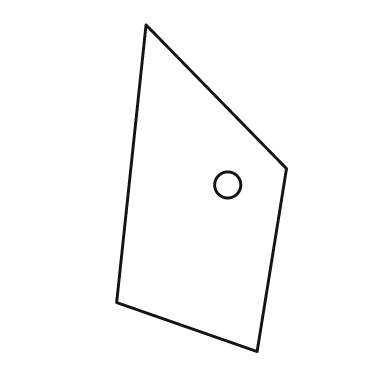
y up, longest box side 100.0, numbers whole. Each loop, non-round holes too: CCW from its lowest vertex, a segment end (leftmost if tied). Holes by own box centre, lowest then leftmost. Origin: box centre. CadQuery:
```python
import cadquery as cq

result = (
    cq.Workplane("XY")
    .moveTo(17.0, -50.0)
    .lineTo(26.0, 6.0)
    .lineTo(-17.0, 50.0)
    .lineTo(-26.0, -35.0)
    .close()
    .moveTo(8.0, 1.0)
    .circle(4.0)
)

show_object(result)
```